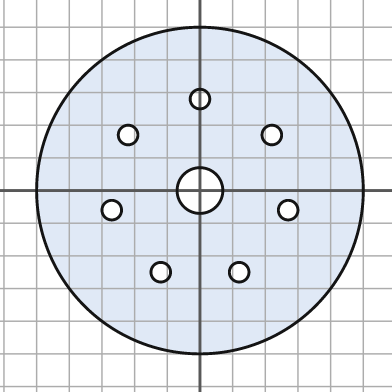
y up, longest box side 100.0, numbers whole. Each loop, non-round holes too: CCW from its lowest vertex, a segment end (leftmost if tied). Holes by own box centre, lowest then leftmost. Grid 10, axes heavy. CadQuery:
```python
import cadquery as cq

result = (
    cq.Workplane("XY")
    .moveTo(0.0, 0.0)
    .circle(50.0)
    .moveTo(-12.0, -25.0)
    .circle(3.0)
    .moveTo(12.0, -25.0)
    .circle(3.0)
    .moveTo(-27.0, -6.0)
    .circle(3.0)
    .moveTo(27.0, -6.0)
    .circle(3.0)
    .moveTo(0.0, 0.0)
    .circle(7.0)
    .moveTo(-22.0, 17.0)
    .circle(3.0)
    .moveTo(22.0, 17.0)
    .circle(3.0)
    .moveTo(0.0, 28.0)
    .circle(3.0)
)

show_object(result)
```